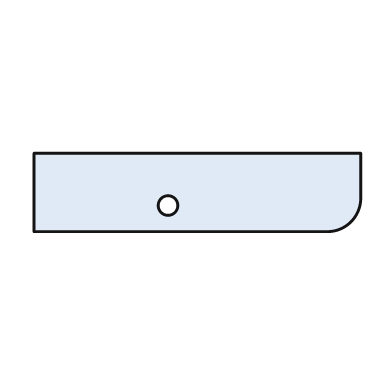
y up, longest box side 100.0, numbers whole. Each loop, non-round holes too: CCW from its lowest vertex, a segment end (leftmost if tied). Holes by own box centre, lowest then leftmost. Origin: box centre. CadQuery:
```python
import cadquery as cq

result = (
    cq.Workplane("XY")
    .moveTo(-50.0, -12.0)
    .lineTo(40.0, -12.0)
    .threePointArc((47.0, -9.0), (50.0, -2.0))
    .lineTo(50.0, 12.0)
    .lineTo(-50.0, 12.0)
    .close()
    .moveTo(-9.0, -4.0)
    .circle(3.0)
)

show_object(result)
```